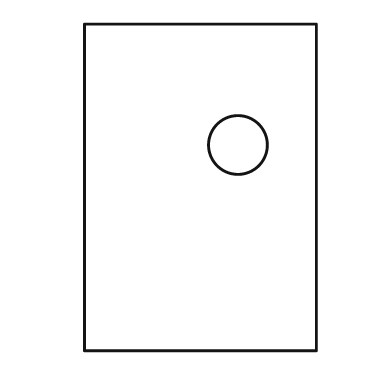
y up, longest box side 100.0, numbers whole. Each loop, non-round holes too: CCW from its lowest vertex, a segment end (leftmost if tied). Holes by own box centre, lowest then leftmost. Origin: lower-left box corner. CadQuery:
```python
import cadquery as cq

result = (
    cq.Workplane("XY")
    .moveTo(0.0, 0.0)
    .lineTo(71.0, 0.0)
    .lineTo(71.0, 100.0)
    .lineTo(0.0, 100.0)
    .close()
    .moveTo(47.0, 63.0)
    .circle(9.0)
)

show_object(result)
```